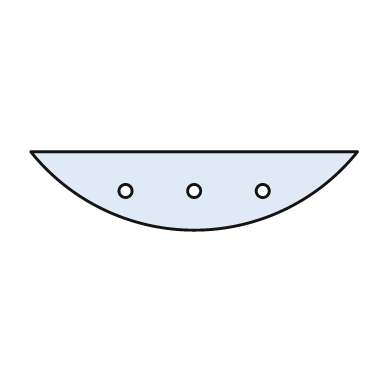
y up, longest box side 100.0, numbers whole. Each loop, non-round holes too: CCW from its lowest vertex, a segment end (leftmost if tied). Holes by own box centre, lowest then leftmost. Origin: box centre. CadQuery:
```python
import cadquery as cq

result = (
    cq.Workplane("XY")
    .moveTo(-50.0, 12.0)
    .threePointArc((0.0, -12.0), (50.0, 12.0))
    .close()
    .moveTo(-21.0, 0.0)
    .circle(2.0)
    .moveTo(0.0, 0.0)
    .circle(2.0)
    .moveTo(21.0, 0.0)
    .circle(2.0)
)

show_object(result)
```